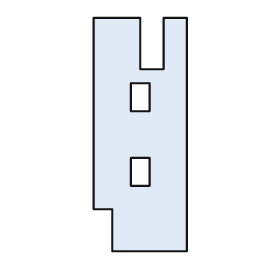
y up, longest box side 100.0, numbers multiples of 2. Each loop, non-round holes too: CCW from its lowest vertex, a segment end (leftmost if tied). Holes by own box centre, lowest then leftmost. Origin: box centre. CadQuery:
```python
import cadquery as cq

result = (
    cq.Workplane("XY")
    .moveTo(-12.0, -50.0)
    .lineTo(20.0, -50.0)
    .lineTo(20.0, 50.0)
    .lineTo(10.0, 50.0)
    .lineTo(10.0, 28.0)
    .lineTo(0.0, 28.0)
    .lineTo(0.0, 50.0)
    .lineTo(-20.0, 50.0)
    .lineTo(-20.0, -32.0)
    .lineTo(-12.0, -32.0)
    .close()
    .moveTo(-4.0, -22.0)
    .lineTo(4.0, -22.0)
    .lineTo(4.0, -10.0)
    .lineTo(-4.0, -10.0)
    .close()
    .moveTo(-4.0, 10.0)
    .lineTo(4.0, 10.0)
    .lineTo(4.0, 22.0)
    .lineTo(-4.0, 22.0)
    .close()
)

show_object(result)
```